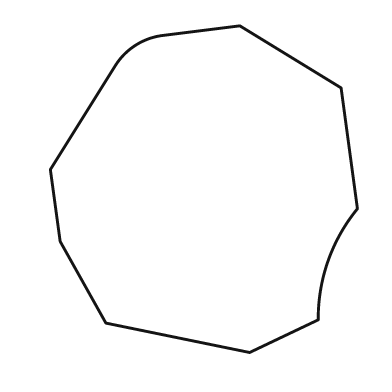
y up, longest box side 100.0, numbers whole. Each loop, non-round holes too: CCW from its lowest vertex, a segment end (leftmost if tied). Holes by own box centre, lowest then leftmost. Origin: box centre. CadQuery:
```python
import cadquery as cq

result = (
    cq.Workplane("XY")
    .moveTo(14.0, -50.0)
    .lineTo(35.0, -40.0)
    .threePointArc((38.0, -22.0), (47.0, -6.0))
    .lineTo(42.0, 31.0)
    .lineTo(11.0, 50.0)
    .lineTo(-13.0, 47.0)
    .threePointArc((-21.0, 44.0), (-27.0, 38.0))
    .lineTo(-47.0, 6.0)
    .lineTo(-44.0, -16.0)
    .lineTo(-30.0, -41.0)
    .close()
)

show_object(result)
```